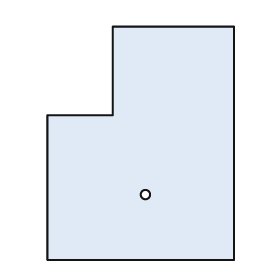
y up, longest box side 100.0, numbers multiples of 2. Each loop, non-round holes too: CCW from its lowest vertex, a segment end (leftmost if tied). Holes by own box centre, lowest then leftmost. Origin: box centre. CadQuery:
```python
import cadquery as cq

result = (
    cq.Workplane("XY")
    .moveTo(-40.0, -50.0)
    .lineTo(40.0, -50.0)
    .lineTo(40.0, 50.0)
    .lineTo(-12.0, 50.0)
    .lineTo(-12.0, 12.0)
    .lineTo(-40.0, 12.0)
    .close()
    .moveTo(2.0, -22.0)
    .circle(2.0)
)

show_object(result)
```